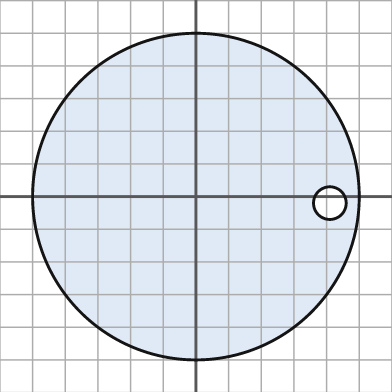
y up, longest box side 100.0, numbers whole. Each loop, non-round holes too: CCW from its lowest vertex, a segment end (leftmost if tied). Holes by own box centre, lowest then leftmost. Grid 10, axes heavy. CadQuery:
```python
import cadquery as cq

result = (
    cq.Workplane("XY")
    .moveTo(0.0, 0.0)
    .circle(50.0)
    .moveTo(41.0, -2.0)
    .circle(5.0)
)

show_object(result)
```